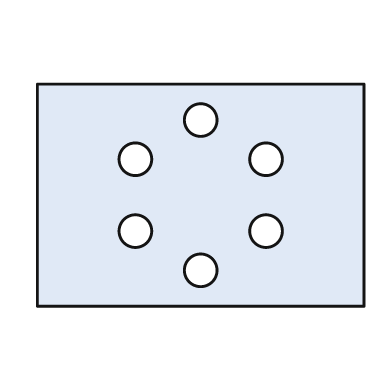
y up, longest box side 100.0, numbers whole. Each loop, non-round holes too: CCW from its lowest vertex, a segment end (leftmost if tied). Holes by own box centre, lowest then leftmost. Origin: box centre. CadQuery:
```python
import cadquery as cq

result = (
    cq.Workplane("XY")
    .moveTo(-50.0, -34.0)
    .lineTo(50.0, -34.0)
    .lineTo(50.0, 34.0)
    .lineTo(-50.0, 34.0)
    .close()
    .moveTo(0.0, -23.0)
    .circle(5.0)
    .moveTo(-20.0, -11.0)
    .circle(5.0)
    .moveTo(20.0, -11.0)
    .circle(5.0)
    .moveTo(-20.0, 11.0)
    .circle(5.0)
    .moveTo(20.0, 11.0)
    .circle(5.0)
    .moveTo(0.0, 23.0)
    .circle(5.0)
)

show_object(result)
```